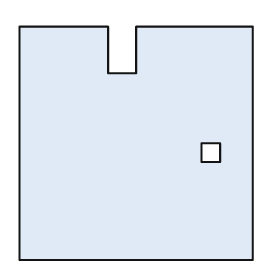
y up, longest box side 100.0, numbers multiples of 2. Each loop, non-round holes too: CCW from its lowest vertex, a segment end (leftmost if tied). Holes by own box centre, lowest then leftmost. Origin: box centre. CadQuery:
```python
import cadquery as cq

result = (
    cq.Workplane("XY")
    .moveTo(-50.0, -50.0)
    .lineTo(50.0, -50.0)
    .lineTo(50.0, 50.0)
    .lineTo(0.0, 50.0)
    .lineTo(0.0, 30.0)
    .lineTo(-12.0, 30.0)
    .lineTo(-12.0, 50.0)
    .lineTo(-50.0, 50.0)
    .close()
    .moveTo(28.0, -8.0)
    .lineTo(36.0, -8.0)
    .lineTo(36.0, 0.0)
    .lineTo(28.0, 0.0)
    .close()
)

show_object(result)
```